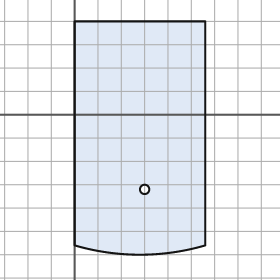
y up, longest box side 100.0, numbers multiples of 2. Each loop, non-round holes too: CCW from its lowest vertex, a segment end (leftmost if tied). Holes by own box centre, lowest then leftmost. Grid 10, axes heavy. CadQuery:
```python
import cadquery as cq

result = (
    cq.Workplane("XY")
    .moveTo(0.0, -56.0)
    .threePointArc((28.0, -60.0), (56.0, -56.0))
    .lineTo(56.0, 40.0)
    .lineTo(0.0, 40.0)
    .close()
    .moveTo(30.0, -32.0)
    .circle(2.0)
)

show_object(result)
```